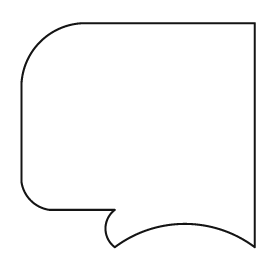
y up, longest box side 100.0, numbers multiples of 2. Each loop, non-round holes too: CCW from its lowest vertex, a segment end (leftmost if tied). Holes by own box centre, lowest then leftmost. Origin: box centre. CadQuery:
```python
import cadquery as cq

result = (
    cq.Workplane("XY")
    .moveTo(-10.0, -48.0)
    .threePointArc((20.0, -38.0), (50.0, -48.0))
    .lineTo(50.0, 48.0)
    .lineTo(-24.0, 48.0)
    .threePointArc((-42.0, 40.0), (-50.0, 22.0))
    .lineTo(-50.0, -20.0)
    .threePointArc((-46.0, -28.0), (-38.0, -32.0))
    .lineTo(-10.0, -32.0)
    .threePointArc((-14.0, -40.0), (-10.0, -48.0))
    .close()
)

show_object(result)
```